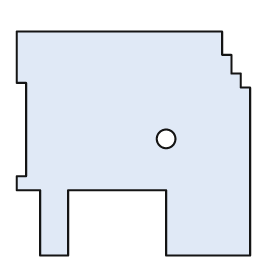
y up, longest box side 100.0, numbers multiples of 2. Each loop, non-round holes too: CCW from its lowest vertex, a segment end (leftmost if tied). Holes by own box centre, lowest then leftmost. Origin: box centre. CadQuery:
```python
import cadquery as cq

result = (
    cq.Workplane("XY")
    .moveTo(-40.0, -48.0)
    .lineTo(-28.0, -48.0)
    .lineTo(-28.0, -20.0)
    .lineTo(14.0, -20.0)
    .lineTo(14.0, -48.0)
    .lineTo(50.0, -48.0)
    .lineTo(50.0, 24.0)
    .lineTo(46.0, 24.0)
    .lineTo(46.0, 30.0)
    .lineTo(42.0, 30.0)
    .lineTo(42.0, 38.0)
    .lineTo(38.0, 38.0)
    .lineTo(38.0, 48.0)
    .lineTo(-50.0, 48.0)
    .lineTo(-50.0, 26.0)
    .lineTo(-46.0, 26.0)
    .lineTo(-46.0, -14.0)
    .lineTo(-50.0, -14.0)
    .lineTo(-50.0, -20.0)
    .lineTo(-40.0, -20.0)
    .close()
    .moveTo(14.0, 2.0)
    .circle(4.0)
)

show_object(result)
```